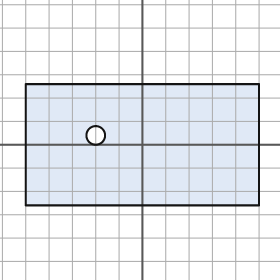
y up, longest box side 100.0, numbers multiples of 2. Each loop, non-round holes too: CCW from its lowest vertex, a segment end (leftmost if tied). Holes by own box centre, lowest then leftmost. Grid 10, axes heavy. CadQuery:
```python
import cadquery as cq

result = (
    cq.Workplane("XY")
    .moveTo(-50.0, -26.0)
    .lineTo(50.0, -26.0)
    .lineTo(50.0, 26.0)
    .lineTo(-50.0, 26.0)
    .close()
    .moveTo(-20.0, 4.0)
    .circle(4.0)
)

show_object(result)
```